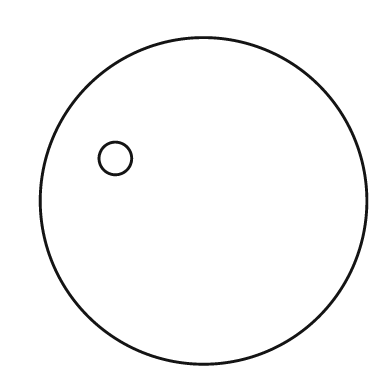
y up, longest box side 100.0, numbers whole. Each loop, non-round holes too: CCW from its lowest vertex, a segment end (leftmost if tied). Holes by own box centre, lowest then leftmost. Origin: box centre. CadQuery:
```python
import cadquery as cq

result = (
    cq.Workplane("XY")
    .moveTo(0.0, 0.0)
    .circle(50.0)
    .moveTo(-27.0, 13.0)
    .circle(5.0)
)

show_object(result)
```